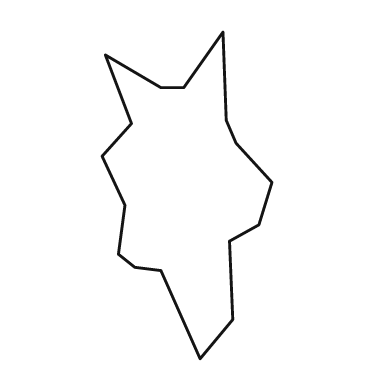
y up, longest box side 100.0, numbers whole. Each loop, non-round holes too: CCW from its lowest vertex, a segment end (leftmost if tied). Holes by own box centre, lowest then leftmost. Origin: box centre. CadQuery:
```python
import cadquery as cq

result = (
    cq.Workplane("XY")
    .moveTo(4.0, -50.0)
    .lineTo(14.0, -38.0)
    .lineTo(13.0, -14.0)
    .lineTo(22.0, -9.0)
    .lineTo(26.0, 4.0)
    .lineTo(15.0, 16.0)
    .lineTo(12.0, 23.0)
    .lineTo(11.0, 50.0)
    .lineTo(-1.0, 33.0)
    .lineTo(-8.0, 33.0)
    .lineTo(-25.0, 43.0)
    .lineTo(-17.0, 22.0)
    .lineTo(-26.0, 12.0)
    .lineTo(-19.0, -3.0)
    .lineTo(-21.0, -18.0)
    .lineTo(-16.0, -22.0)
    .lineTo(-8.0, -23.0)
    .close()
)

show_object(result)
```